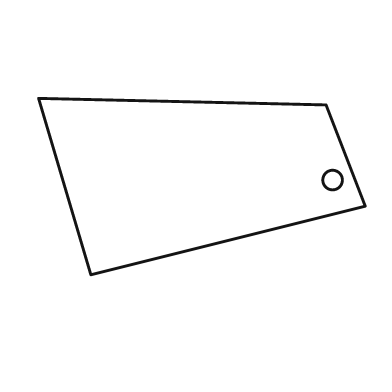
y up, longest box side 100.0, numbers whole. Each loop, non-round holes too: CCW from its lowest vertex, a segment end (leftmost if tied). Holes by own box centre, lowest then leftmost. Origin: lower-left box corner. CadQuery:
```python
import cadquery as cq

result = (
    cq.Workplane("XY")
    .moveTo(16.0, 0.0)
    .lineTo(100.0, 21.0)
    .lineTo(88.0, 52.0)
    .lineTo(0.0, 54.0)
    .close()
    .moveTo(90.0, 29.0)
    .circle(3.0)
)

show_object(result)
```